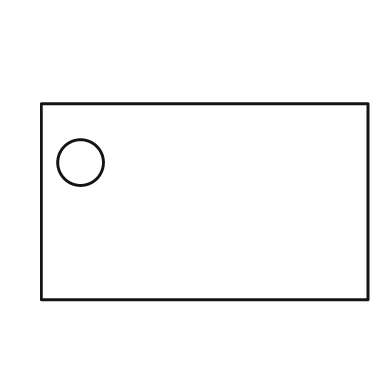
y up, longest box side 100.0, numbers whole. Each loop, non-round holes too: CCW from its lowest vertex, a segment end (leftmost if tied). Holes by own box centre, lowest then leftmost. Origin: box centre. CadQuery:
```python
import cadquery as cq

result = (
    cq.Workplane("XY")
    .moveTo(-50.0, -30.0)
    .lineTo(50.0, -30.0)
    .lineTo(50.0, 30.0)
    .lineTo(-50.0, 30.0)
    .close()
    .moveTo(-38.0, 12.0)
    .circle(7.0)
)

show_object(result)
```